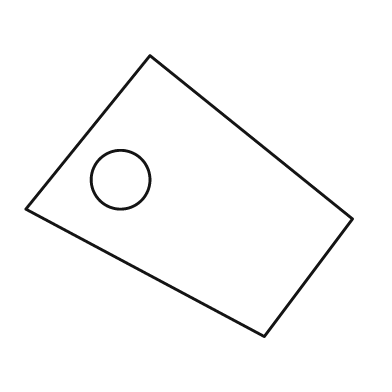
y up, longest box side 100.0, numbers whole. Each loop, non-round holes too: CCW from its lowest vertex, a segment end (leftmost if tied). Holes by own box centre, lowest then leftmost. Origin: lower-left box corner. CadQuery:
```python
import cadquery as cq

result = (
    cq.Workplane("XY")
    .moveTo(73.0, 0.0)
    .lineTo(100.0, 36.0)
    .lineTo(38.0, 86.0)
    .lineTo(0.0, 39.0)
    .close()
    .moveTo(29.0, 48.0)
    .circle(9.0)
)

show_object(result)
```